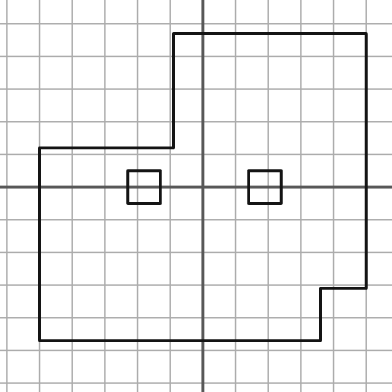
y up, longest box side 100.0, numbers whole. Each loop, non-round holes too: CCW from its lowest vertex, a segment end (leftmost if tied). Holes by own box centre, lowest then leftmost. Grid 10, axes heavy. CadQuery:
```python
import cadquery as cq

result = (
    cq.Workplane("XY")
    .moveTo(-50.0, -47.0)
    .lineTo(36.0, -47.0)
    .lineTo(36.0, -31.0)
    .lineTo(50.0, -31.0)
    .lineTo(50.0, 47.0)
    .lineTo(-9.0, 47.0)
    .lineTo(-9.0, 12.0)
    .lineTo(-50.0, 12.0)
    .close()
    .moveTo(-23.0, -5.0)
    .lineTo(-13.0, -5.0)
    .lineTo(-13.0, 5.0)
    .lineTo(-23.0, 5.0)
    .close()
    .moveTo(14.0, -5.0)
    .lineTo(24.0, -5.0)
    .lineTo(24.0, 5.0)
    .lineTo(14.0, 5.0)
    .close()
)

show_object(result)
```